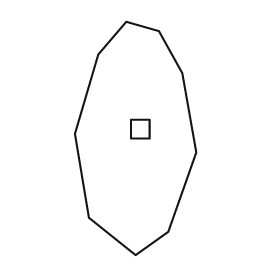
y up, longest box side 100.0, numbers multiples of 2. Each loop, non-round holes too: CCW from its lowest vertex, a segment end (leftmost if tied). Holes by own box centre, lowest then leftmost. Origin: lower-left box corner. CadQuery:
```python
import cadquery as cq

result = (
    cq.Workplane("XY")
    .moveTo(26.0, 0.0)
    .lineTo(40.0, 10.0)
    .lineTo(52.0, 44.0)
    .lineTo(46.0, 78.0)
    .lineTo(36.0, 96.0)
    .lineTo(22.0, 100.0)
    .lineTo(10.0, 86.0)
    .lineTo(0.0, 52.0)
    .lineTo(6.0, 16.0)
    .close()
    .moveTo(24.0, 50.0)
    .lineTo(32.0, 50.0)
    .lineTo(32.0, 58.0)
    .lineTo(24.0, 58.0)
    .close()
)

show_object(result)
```